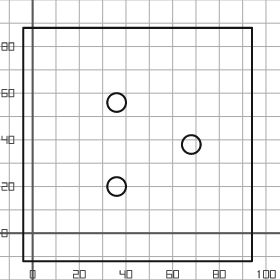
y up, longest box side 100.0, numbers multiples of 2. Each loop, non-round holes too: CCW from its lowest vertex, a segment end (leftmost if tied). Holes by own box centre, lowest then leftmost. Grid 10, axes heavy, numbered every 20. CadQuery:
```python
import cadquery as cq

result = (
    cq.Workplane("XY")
    .moveTo(-4.0, -12.0)
    .lineTo(94.0, -12.0)
    .lineTo(94.0, 88.0)
    .lineTo(-4.0, 88.0)
    .close()
    .moveTo(36.0, 20.0)
    .circle(4.0)
    .moveTo(68.0, 38.0)
    .circle(4.0)
    .moveTo(36.0, 56.0)
    .circle(4.0)
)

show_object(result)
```